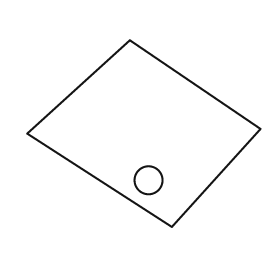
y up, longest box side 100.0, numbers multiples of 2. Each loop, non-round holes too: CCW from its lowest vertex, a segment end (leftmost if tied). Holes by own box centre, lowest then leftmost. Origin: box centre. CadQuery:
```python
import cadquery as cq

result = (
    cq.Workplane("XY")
    .moveTo(12.0, -40.0)
    .lineTo(50.0, 2.0)
    .lineTo(-6.0, 40.0)
    .lineTo(-50.0, 0.0)
    .close()
    .moveTo(2.0, -20.0)
    .circle(6.0)
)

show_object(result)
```